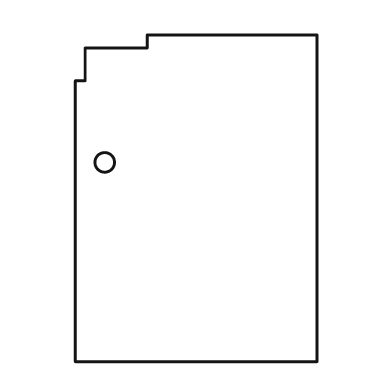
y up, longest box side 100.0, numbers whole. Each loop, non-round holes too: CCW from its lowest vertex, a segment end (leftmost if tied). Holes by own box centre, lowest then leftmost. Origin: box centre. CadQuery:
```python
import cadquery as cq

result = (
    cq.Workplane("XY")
    .moveTo(-37.0, -50.0)
    .lineTo(37.0, -50.0)
    .lineTo(37.0, 50.0)
    .lineTo(-15.0, 50.0)
    .lineTo(-15.0, 46.0)
    .lineTo(-34.0, 46.0)
    .lineTo(-34.0, 36.0)
    .lineTo(-37.0, 36.0)
    .close()
    .moveTo(-28.0, 11.0)
    .circle(3.0)
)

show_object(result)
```